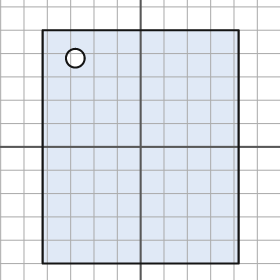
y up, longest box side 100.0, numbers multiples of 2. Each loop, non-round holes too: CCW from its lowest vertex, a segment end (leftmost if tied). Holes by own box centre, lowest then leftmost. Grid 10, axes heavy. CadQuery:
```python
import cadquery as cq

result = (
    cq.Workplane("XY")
    .moveTo(-42.0, -50.0)
    .lineTo(42.0, -50.0)
    .lineTo(42.0, 50.0)
    .lineTo(-42.0, 50.0)
    .close()
    .moveTo(-28.0, 38.0)
    .circle(4.0)
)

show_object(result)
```